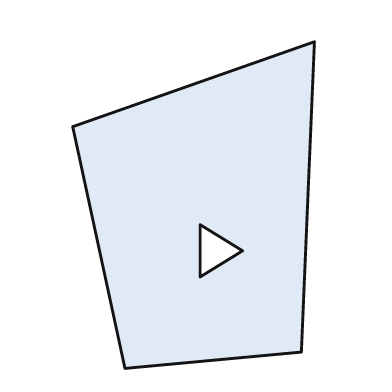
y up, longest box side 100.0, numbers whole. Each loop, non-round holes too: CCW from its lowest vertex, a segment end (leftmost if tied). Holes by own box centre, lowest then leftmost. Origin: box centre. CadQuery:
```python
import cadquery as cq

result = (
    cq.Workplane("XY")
    .moveTo(-21.0, -50.0)
    .lineTo(33.0, -45.0)
    .lineTo(37.0, 50.0)
    .lineTo(-37.0, 24.0)
    .close()
    .moveTo(2.0, -22.0)
    .lineTo(15.0, -14.0)
    .lineTo(2.0, -6.0)
    .close()
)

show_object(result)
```